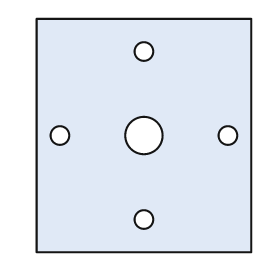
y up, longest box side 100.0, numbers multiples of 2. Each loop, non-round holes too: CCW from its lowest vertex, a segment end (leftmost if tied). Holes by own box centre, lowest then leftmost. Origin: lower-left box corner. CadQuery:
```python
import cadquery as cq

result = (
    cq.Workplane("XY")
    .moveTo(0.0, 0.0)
    .lineTo(92.0, 0.0)
    .lineTo(92.0, 100.0)
    .lineTo(0.0, 100.0)
    .close()
    .moveTo(46.0, 14.0)
    .circle(4.0)
    .moveTo(10.0, 50.0)
    .circle(4.0)
    .moveTo(46.0, 50.0)
    .circle(8.0)
    .moveTo(82.0, 50.0)
    .circle(4.0)
    .moveTo(46.0, 86.0)
    .circle(4.0)
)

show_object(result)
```